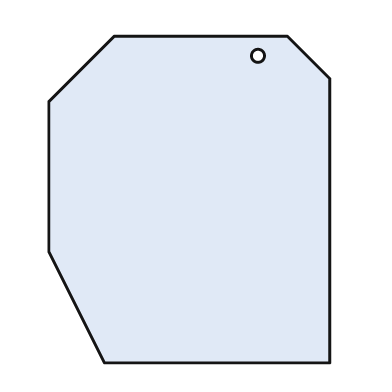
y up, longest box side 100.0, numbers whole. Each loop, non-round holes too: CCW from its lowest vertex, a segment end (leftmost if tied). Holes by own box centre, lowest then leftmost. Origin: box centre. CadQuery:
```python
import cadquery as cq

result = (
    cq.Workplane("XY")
    .moveTo(-26.0, -50.0)
    .lineTo(43.0, -50.0)
    .lineTo(43.0, 37.0)
    .lineTo(30.0, 50.0)
    .lineTo(-23.0, 50.0)
    .lineTo(-43.0, 30.0)
    .lineTo(-43.0, -16.0)
    .close()
    .moveTo(21.0, 44.0)
    .circle(2.0)
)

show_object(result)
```